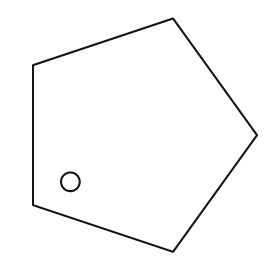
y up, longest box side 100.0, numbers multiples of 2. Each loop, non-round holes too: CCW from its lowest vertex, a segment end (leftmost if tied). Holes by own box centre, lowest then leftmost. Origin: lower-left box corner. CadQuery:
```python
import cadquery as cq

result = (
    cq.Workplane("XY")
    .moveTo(60.0, 0.0)
    .lineTo(96.0, 50.0)
    .lineTo(60.0, 100.0)
    .lineTo(0.0, 80.0)
    .lineTo(0.0, 20.0)
    .close()
    .moveTo(16.0, 30.0)
    .circle(4.0)
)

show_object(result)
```